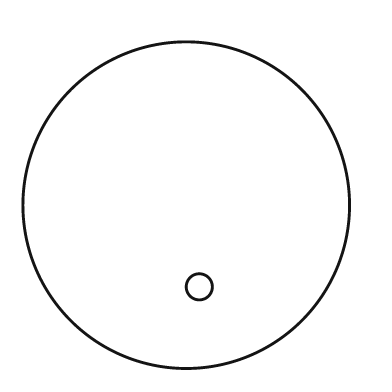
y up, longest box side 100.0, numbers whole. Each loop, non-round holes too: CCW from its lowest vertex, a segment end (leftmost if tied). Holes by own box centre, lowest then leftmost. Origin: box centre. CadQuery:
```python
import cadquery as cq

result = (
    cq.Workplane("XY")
    .moveTo(0.0, 0.0)
    .circle(50.0)
    .moveTo(4.0, -25.0)
    .circle(4.0)
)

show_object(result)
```